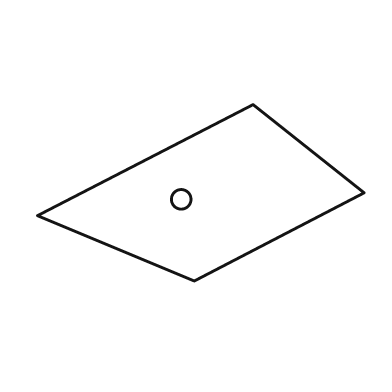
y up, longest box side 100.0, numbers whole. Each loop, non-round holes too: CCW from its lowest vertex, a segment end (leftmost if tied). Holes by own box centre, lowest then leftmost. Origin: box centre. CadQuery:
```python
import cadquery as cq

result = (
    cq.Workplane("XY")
    .moveTo(-2.0, -27.0)
    .lineTo(50.0, 0.0)
    .lineTo(16.0, 27.0)
    .lineTo(-50.0, -7.0)
    .close()
    .moveTo(-6.0, -2.0)
    .circle(3.0)
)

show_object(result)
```